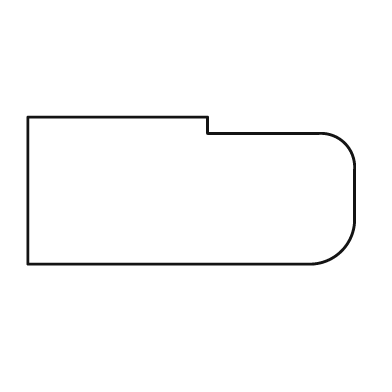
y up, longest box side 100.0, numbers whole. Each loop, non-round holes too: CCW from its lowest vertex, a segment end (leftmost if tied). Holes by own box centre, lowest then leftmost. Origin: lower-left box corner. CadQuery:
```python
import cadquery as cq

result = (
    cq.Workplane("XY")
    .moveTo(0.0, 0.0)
    .lineTo(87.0, 0.0)
    .threePointArc((96.0, 4.0), (100.0, 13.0))
    .lineTo(100.0, 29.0)
    .threePointArc((97.0, 37.0), (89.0, 40.0))
    .lineTo(55.0, 40.0)
    .lineTo(55.0, 45.0)
    .lineTo(0.0, 45.0)
    .close()
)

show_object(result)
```